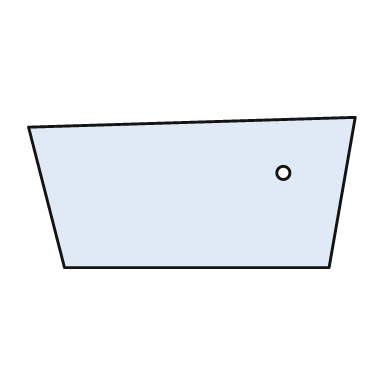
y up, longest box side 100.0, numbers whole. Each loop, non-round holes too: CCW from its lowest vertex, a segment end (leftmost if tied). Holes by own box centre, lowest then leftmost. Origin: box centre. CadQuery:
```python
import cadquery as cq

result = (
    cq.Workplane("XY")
    .moveTo(-39.0, -23.0)
    .lineTo(42.0, -23.0)
    .lineTo(50.0, 23.0)
    .lineTo(-50.0, 20.0)
    .close()
    .moveTo(28.0, 6.0)
    .circle(2.0)
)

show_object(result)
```